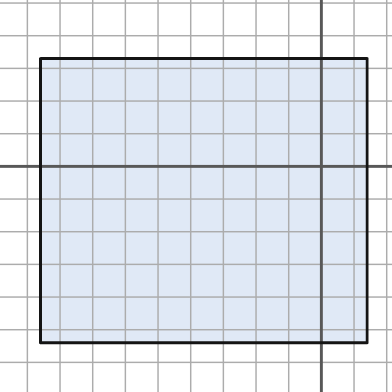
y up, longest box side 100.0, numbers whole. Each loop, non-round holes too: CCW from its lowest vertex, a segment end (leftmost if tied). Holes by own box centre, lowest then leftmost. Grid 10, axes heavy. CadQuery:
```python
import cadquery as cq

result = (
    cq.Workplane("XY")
    .moveTo(-86.0, -54.0)
    .lineTo(14.0, -54.0)
    .lineTo(14.0, 33.0)
    .lineTo(-86.0, 33.0)
    .close()
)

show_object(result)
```